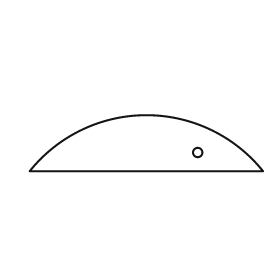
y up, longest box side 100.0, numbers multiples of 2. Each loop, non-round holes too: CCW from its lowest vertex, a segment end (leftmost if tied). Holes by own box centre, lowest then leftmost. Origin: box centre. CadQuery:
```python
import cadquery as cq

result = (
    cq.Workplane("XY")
    .moveTo(-50.0, -12.0)
    .lineTo(50.0, -12.0)
    .threePointArc((0.0, 12.0), (-50.0, -12.0))
    .close()
    .moveTo(22.0, -4.0)
    .circle(2.0)
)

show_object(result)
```